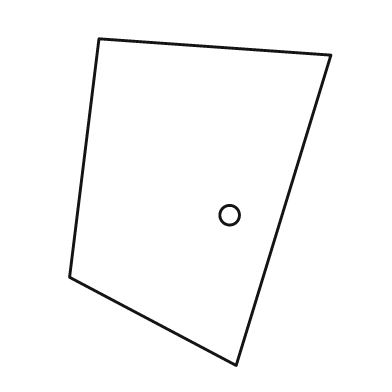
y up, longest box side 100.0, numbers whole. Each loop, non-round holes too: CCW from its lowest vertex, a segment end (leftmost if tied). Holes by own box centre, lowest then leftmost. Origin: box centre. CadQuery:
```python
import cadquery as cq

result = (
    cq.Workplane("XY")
    .moveTo(11.0, -50.0)
    .lineTo(40.0, 45.0)
    .lineTo(-31.0, 50.0)
    .lineTo(-40.0, -23.0)
    .close()
    .moveTo(9.0, -4.0)
    .circle(3.0)
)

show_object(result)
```